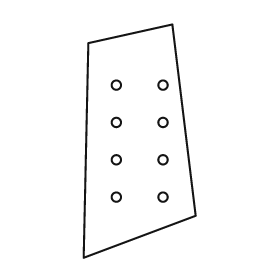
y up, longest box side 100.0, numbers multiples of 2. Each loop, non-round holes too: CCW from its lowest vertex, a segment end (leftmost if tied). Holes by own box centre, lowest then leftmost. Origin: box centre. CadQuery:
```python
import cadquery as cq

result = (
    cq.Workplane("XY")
    .moveTo(-24.0, -50.0)
    .lineTo(24.0, -32.0)
    .lineTo(14.0, 50.0)
    .lineTo(-22.0, 42.0)
    .close()
    .moveTo(-10.0, -24.0)
    .circle(2.0)
    .moveTo(10.0, -24.0)
    .circle(2.0)
    .moveTo(-10.0, -8.0)
    .circle(2.0)
    .moveTo(10.0, -8.0)
    .circle(2.0)
    .moveTo(-10.0, 8.0)
    .circle(2.0)
    .moveTo(10.0, 8.0)
    .circle(2.0)
    .moveTo(-10.0, 24.0)
    .circle(2.0)
    .moveTo(10.0, 24.0)
    .circle(2.0)
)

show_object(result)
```